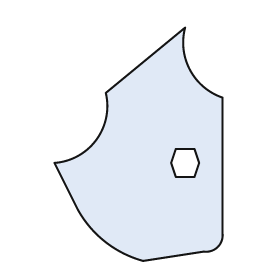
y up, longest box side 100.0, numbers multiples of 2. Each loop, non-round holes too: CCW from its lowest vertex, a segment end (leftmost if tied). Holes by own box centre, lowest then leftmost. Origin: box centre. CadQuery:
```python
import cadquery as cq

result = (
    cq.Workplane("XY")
    .moveTo(2.0, -50.0)
    .lineTo(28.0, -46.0)
    .threePointArc((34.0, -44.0), (36.0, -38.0))
    .lineTo(36.0, 20.0)
    .threePointArc((22.0, 32.0), (20.0, 50.0))
    .lineTo(-14.0, 22.0)
    .threePointArc((-18.0, 2.0), (-36.0, -8.0))
    .lineTo(-26.0, -28.0)
    .threePointArc((-14.0, -42.0), (2.0, -50.0))
    .close()
    .moveTo(16.0, -14.0)
    .lineTo(24.0, -14.0)
    .lineTo(26.0, -8.0)
    .lineTo(24.0, -2.0)
    .lineTo(16.0, -2.0)
    .lineTo(14.0, -8.0)
    .close()
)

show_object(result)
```